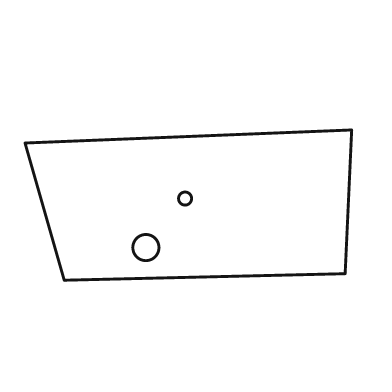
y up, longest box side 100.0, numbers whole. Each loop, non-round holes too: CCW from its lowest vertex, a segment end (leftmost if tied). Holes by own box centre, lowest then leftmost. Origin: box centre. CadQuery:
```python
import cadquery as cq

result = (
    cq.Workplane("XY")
    .moveTo(-38.0, -23.0)
    .lineTo(48.0, -21.0)
    .lineTo(50.0, 23.0)
    .lineTo(-50.0, 19.0)
    .close()
    .moveTo(-13.0, -13.0)
    .circle(4.0)
    .moveTo(-1.0, 2.0)
    .circle(2.0)
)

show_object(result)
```